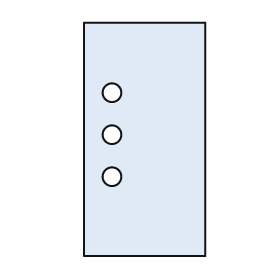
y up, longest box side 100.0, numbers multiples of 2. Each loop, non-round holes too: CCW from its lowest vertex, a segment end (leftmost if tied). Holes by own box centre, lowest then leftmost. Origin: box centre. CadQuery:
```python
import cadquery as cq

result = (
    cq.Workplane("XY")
    .moveTo(-26.0, -50.0)
    .lineTo(26.0, -50.0)
    .lineTo(26.0, 50.0)
    .lineTo(-26.0, 50.0)
    .close()
    .moveTo(-14.0, -16.0)
    .circle(4.0)
    .moveTo(-14.0, 2.0)
    .circle(4.0)
    .moveTo(-14.0, 20.0)
    .circle(4.0)
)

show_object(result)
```